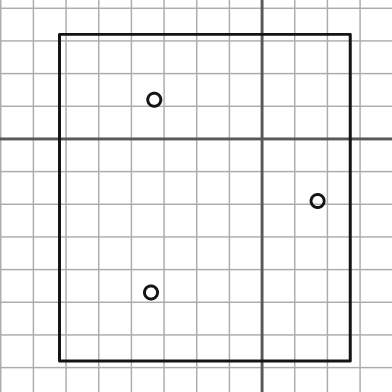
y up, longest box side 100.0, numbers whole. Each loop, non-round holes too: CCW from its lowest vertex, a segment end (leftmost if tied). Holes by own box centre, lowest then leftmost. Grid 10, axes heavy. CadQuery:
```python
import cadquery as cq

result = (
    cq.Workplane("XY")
    .moveTo(-62.0, -68.0)
    .lineTo(27.0, -68.0)
    .lineTo(27.0, 32.0)
    .lineTo(-62.0, 32.0)
    .close()
    .moveTo(-34.0, -47.0)
    .circle(2.0)
    .moveTo(17.0, -19.0)
    .circle(2.0)
    .moveTo(-33.0, 12.0)
    .circle(2.0)
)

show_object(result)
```